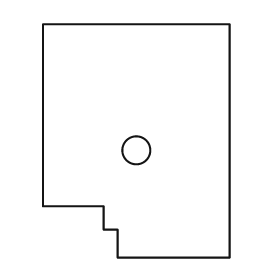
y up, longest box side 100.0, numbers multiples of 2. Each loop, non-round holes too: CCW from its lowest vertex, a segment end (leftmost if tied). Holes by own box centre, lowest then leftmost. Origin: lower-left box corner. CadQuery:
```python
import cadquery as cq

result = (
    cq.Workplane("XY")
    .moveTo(32.0, 0.0)
    .lineTo(80.0, 0.0)
    .lineTo(80.0, 100.0)
    .lineTo(0.0, 100.0)
    .lineTo(0.0, 22.0)
    .lineTo(26.0, 22.0)
    .lineTo(26.0, 12.0)
    .lineTo(32.0, 12.0)
    .close()
    .moveTo(40.0, 46.0)
    .circle(6.0)
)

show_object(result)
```